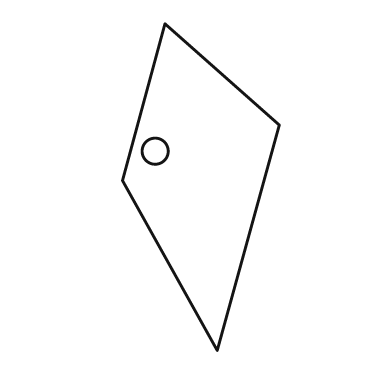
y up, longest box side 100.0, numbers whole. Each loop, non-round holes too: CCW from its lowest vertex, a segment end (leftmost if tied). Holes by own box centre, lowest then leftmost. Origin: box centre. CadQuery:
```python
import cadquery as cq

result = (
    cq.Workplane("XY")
    .moveTo(5.0, -50.0)
    .lineTo(24.0, 19.0)
    .lineTo(-11.0, 50.0)
    .lineTo(-24.0, 2.0)
    .close()
    .moveTo(-14.0, 11.0)
    .circle(4.0)
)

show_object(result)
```